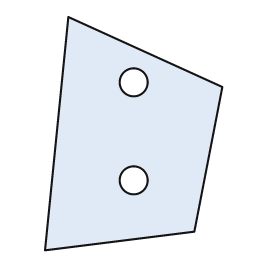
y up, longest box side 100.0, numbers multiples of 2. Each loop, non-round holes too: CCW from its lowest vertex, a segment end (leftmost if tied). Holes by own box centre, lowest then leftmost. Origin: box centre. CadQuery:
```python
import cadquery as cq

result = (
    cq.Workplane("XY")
    .moveTo(-38.0, -50.0)
    .lineTo(26.0, -42.0)
    .lineTo(38.0, 20.0)
    .lineTo(-28.0, 50.0)
    .close()
    .moveTo(0.0, -20.0)
    .circle(6.0)
    .moveTo(0.0, 22.0)
    .circle(6.0)
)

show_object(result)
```